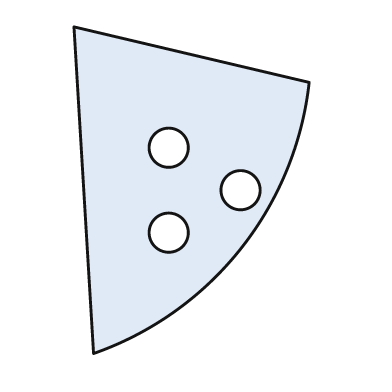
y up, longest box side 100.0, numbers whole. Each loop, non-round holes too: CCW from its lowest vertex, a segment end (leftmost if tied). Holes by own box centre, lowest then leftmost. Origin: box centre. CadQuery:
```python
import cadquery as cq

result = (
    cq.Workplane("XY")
    .moveTo(-30.0, -50.0)
    .threePointArc((15.0, -18.0), (36.0, 33.0))
    .lineTo(-36.0, 50.0)
    .close()
    .moveTo(-7.0, -13.0)
    .circle(6.0)
    .moveTo(15.0, 0.0)
    .circle(6.0)
    .moveTo(-7.0, 13.0)
    .circle(6.0)
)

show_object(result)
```